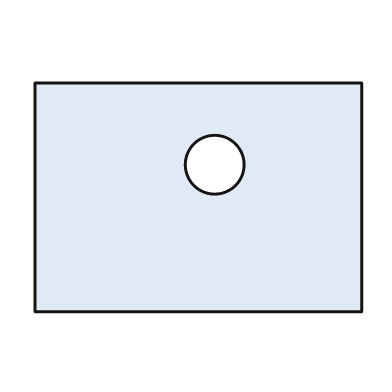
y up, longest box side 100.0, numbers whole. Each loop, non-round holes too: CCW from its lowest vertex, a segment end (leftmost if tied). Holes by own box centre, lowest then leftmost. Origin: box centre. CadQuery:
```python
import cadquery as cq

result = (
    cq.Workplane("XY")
    .moveTo(-50.0, -35.0)
    .lineTo(50.0, -35.0)
    .lineTo(50.0, 35.0)
    .lineTo(-50.0, 35.0)
    .close()
    .moveTo(5.0, 10.0)
    .circle(9.0)
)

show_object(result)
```